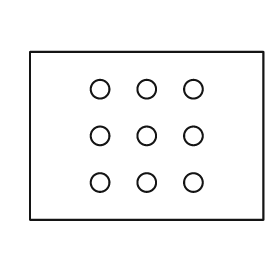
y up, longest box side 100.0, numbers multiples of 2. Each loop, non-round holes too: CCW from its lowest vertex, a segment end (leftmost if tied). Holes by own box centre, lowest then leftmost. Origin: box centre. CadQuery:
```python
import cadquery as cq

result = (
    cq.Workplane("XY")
    .moveTo(-50.0, -36.0)
    .lineTo(50.0, -36.0)
    .lineTo(50.0, 36.0)
    .lineTo(-50.0, 36.0)
    .close()
    .moveTo(-20.0, -20.0)
    .circle(4.0)
    .moveTo(0.0, -20.0)
    .circle(4.0)
    .moveTo(20.0, -20.0)
    .circle(4.0)
    .moveTo(-20.0, 0.0)
    .circle(4.0)
    .moveTo(0.0, 0.0)
    .circle(4.0)
    .moveTo(20.0, 0.0)
    .circle(4.0)
    .moveTo(-20.0, 20.0)
    .circle(4.0)
    .moveTo(0.0, 20.0)
    .circle(4.0)
    .moveTo(20.0, 20.0)
    .circle(4.0)
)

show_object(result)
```